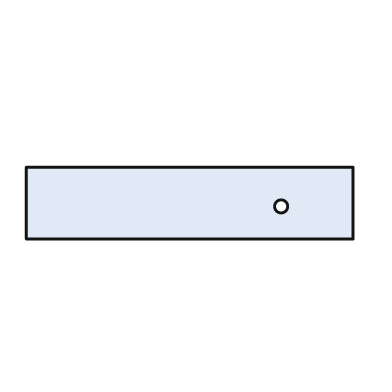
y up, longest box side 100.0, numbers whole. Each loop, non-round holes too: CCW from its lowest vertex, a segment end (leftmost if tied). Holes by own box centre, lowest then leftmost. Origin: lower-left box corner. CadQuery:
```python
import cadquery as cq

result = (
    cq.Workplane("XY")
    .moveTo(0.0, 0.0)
    .lineTo(100.0, 0.0)
    .lineTo(100.0, 22.0)
    .lineTo(0.0, 22.0)
    .close()
    .moveTo(78.0, 10.0)
    .circle(2.0)
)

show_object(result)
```